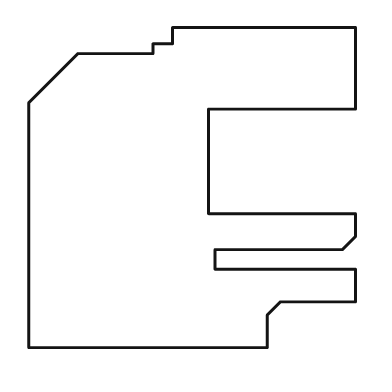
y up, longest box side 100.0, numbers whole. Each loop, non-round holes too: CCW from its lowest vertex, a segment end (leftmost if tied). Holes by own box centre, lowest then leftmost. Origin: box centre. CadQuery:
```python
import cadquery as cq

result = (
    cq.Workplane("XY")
    .moveTo(-50.0, -49.0)
    .lineTo(23.0, -49.0)
    .lineTo(23.0, -39.0)
    .lineTo(27.0, -35.0)
    .lineTo(50.0, -35.0)
    .lineTo(50.0, -25.0)
    .lineTo(7.0, -25.0)
    .lineTo(7.0, -19.0)
    .lineTo(46.0, -19.0)
    .lineTo(50.0, -15.0)
    .lineTo(50.0, -8.0)
    .lineTo(5.0, -8.0)
    .lineTo(5.0, 24.0)
    .lineTo(50.0, 24.0)
    .lineTo(50.0, 49.0)
    .lineTo(-6.0, 49.0)
    .lineTo(-6.0, 44.0)
    .lineTo(-12.0, 44.0)
    .lineTo(-12.0, 41.0)
    .lineTo(-35.0, 41.0)
    .lineTo(-50.0, 26.0)
    .close()
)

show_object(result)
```